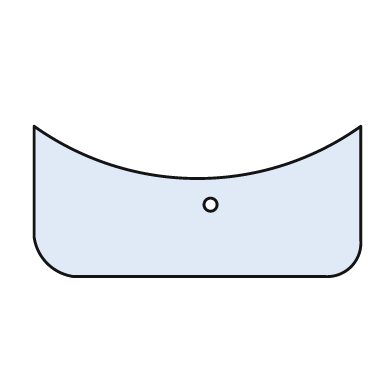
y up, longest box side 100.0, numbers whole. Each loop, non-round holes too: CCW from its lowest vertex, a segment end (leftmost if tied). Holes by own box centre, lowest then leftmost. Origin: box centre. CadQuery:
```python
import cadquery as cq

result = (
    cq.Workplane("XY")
    .moveTo(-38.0, -23.0)
    .lineTo(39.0, -23.0)
    .threePointArc((47.0, -20.0), (50.0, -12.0))
    .lineTo(50.0, 23.0)
    .threePointArc((0.0, 7.0), (-50.0, 23.0))
    .lineTo(-50.0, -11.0)
    .threePointArc((-46.0, -19.0), (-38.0, -23.0))
    .close()
    .moveTo(4.0, -1.0)
    .circle(2.0)
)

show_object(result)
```